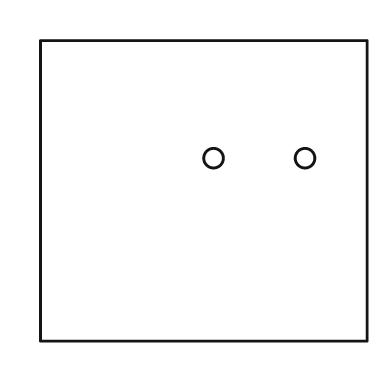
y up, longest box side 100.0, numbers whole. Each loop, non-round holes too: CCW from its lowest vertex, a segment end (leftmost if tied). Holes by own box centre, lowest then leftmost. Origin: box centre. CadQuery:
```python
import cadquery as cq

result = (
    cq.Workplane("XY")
    .moveTo(-50.0, -46.0)
    .lineTo(50.0, -46.0)
    .lineTo(50.0, 46.0)
    .lineTo(-50.0, 46.0)
    .close()
    .moveTo(3.0, 10.0)
    .circle(3.0)
    .moveTo(31.0, 10.0)
    .circle(3.0)
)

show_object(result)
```